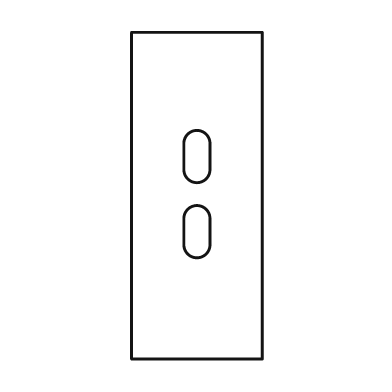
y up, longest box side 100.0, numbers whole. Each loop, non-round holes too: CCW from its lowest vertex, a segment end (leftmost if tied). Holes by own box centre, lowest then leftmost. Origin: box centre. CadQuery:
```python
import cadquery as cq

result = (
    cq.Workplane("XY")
    .moveTo(-20.0, -50.0)
    .lineTo(20.0, -50.0)
    .lineTo(20.0, 50.0)
    .lineTo(-20.0, 50.0)
    .close()
    .moveTo(-4.0, -15.0)
    .threePointArc((0.0, -19.0), (4.0, -15.0))
    .lineTo(4.0, -7.0)
    .threePointArc((0.0, -3.0), (-4.0, -7.0))
    .close()
    .moveTo(-4.0, 8.0)
    .threePointArc((0.0, 4.0), (4.0, 8.0))
    .lineTo(4.0, 16.0)
    .threePointArc((0.0, 20.0), (-4.0, 16.0))
    .close()
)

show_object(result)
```